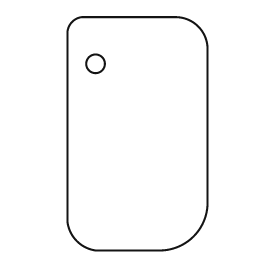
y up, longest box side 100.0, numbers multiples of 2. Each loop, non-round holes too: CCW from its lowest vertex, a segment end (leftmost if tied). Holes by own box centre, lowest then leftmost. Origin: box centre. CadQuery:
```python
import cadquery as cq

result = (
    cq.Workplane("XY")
    .moveTo(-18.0, -50.0)
    .lineTo(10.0, -50.0)
    .threePointArc((24.0, -44.0), (30.0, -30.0))
    .lineTo(30.0, 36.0)
    .threePointArc((26.0, 46.0), (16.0, 50.0))
    .lineTo(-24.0, 50.0)
    .threePointArc((-28.0, 48.0), (-30.0, 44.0))
    .lineTo(-30.0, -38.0)
    .threePointArc((-26.0, -46.0), (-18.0, -50.0))
    .close()
    .moveTo(-18.0, 30.0)
    .circle(4.0)
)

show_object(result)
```